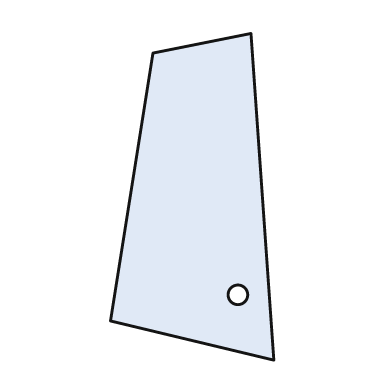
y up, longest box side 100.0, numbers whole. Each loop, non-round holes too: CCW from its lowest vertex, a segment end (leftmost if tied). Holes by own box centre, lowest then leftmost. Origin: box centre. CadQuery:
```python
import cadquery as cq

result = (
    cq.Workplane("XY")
    .moveTo(25.0, -50.0)
    .lineTo(18.0, 50.0)
    .lineTo(-12.0, 44.0)
    .lineTo(-25.0, -38.0)
    .close()
    .moveTo(14.0, -30.0)
    .circle(3.0)
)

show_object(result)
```